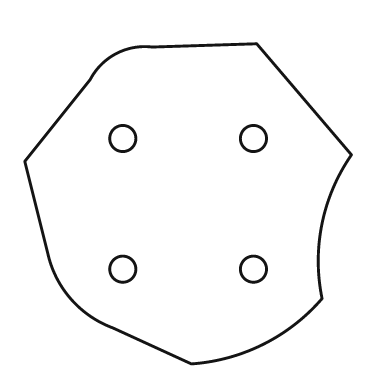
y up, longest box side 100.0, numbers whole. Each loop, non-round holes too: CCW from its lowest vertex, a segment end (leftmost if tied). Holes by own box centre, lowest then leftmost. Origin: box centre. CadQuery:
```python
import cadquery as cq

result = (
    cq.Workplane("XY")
    .moveTo(1.0, -49.0)
    .threePointArc((23.0, -43.0), (41.0, -29.0))
    .threePointArc((41.0, -6.0), (50.0, 15.0))
    .lineTo(21.0, 49.0)
    .lineTo(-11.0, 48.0)
    .threePointArc((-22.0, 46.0), (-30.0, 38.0))
    .lineTo(-50.0, 13.0)
    .lineTo(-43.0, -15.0)
    .threePointArc((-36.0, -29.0), (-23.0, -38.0))
    .close()
    .moveTo(-20.0, -20.0)
    .circle(4.0)
    .moveTo(20.0, -20.0)
    .circle(4.0)
    .moveTo(-20.0, 20.0)
    .circle(4.0)
    .moveTo(20.0, 20.0)
    .circle(4.0)
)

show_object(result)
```